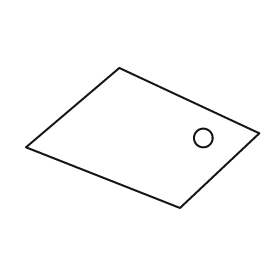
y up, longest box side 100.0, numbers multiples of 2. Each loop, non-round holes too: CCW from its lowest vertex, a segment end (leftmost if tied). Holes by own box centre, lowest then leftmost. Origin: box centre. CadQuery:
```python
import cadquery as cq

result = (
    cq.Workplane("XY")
    .moveTo(16.0, -30.0)
    .lineTo(50.0, 2.0)
    .lineTo(-10.0, 30.0)
    .lineTo(-50.0, -4.0)
    .close()
    .moveTo(26.0, 0.0)
    .circle(4.0)
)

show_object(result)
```